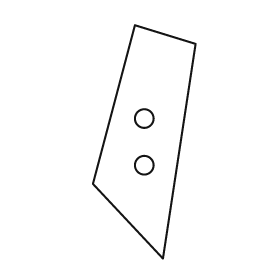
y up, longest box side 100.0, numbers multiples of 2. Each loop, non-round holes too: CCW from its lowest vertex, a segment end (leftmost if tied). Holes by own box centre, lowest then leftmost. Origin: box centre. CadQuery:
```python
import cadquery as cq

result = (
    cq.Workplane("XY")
    .moveTo(8.0, -50.0)
    .lineTo(22.0, 42.0)
    .lineTo(-4.0, 50.0)
    .lineTo(-22.0, -18.0)
    .close()
    .moveTo(0.0, -10.0)
    .circle(4.0)
    .moveTo(0.0, 10.0)
    .circle(4.0)
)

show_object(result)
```